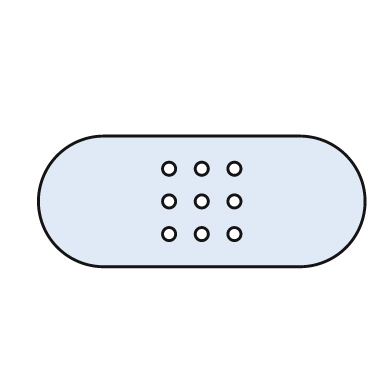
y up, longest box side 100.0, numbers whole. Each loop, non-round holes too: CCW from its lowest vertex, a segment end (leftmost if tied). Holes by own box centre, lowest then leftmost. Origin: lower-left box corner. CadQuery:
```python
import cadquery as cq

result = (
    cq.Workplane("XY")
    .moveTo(20.0, 0.0)
    .lineTo(80.0, 0.0)
    .threePointArc((100.0, 20.0), (80.0, 40.0))
    .lineTo(20.0, 40.0)
    .threePointArc((0.0, 20.0), (20.0, 0.0))
    .close()
    .moveTo(40.0, 10.0)
    .circle(2.0)
    .moveTo(50.0, 10.0)
    .circle(2.0)
    .moveTo(60.0, 10.0)
    .circle(2.0)
    .moveTo(40.0, 20.0)
    .circle(2.0)
    .moveTo(50.0, 20.0)
    .circle(2.0)
    .moveTo(60.0, 20.0)
    .circle(2.0)
    .moveTo(40.0, 30.0)
    .circle(2.0)
    .moveTo(50.0, 30.0)
    .circle(2.0)
    .moveTo(60.0, 30.0)
    .circle(2.0)
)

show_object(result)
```